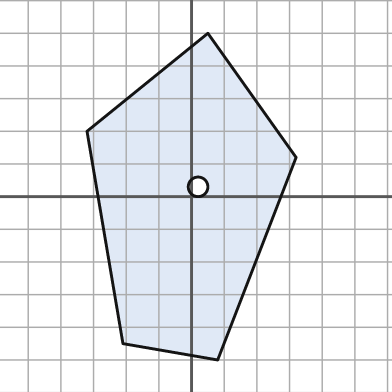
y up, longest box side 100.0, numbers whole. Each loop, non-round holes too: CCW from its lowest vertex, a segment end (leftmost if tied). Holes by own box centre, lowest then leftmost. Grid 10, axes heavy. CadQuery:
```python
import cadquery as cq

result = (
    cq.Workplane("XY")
    .moveTo(8.0, -50.0)
    .lineTo(32.0, 12.0)
    .lineTo(5.0, 50.0)
    .lineTo(-32.0, 20.0)
    .lineTo(-21.0, -45.0)
    .close()
    .moveTo(2.0, 3.0)
    .circle(3.0)
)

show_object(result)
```